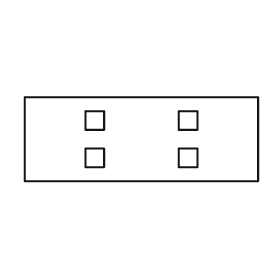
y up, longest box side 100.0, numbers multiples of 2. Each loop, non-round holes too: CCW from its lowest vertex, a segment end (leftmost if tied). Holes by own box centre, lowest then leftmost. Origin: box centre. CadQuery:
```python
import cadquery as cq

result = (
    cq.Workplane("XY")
    .moveTo(-50.0, -18.0)
    .lineTo(50.0, -18.0)
    .lineTo(50.0, 18.0)
    .lineTo(-50.0, 18.0)
    .close()
    .moveTo(-24.0, -12.0)
    .lineTo(-16.0, -12.0)
    .lineTo(-16.0, -4.0)
    .lineTo(-24.0, -4.0)
    .close()
    .moveTo(16.0, -12.0)
    .lineTo(24.0, -12.0)
    .lineTo(24.0, -4.0)
    .lineTo(16.0, -4.0)
    .close()
    .moveTo(-24.0, 4.0)
    .lineTo(-16.0, 4.0)
    .lineTo(-16.0, 12.0)
    .lineTo(-24.0, 12.0)
    .close()
    .moveTo(16.0, 4.0)
    .lineTo(24.0, 4.0)
    .lineTo(24.0, 12.0)
    .lineTo(16.0, 12.0)
    .close()
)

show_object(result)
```